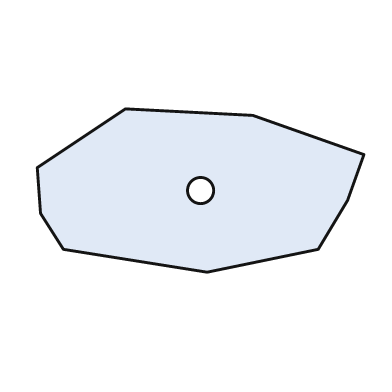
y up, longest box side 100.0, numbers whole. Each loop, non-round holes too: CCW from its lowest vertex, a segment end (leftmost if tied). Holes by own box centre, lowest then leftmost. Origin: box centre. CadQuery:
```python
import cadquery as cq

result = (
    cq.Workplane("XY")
    .moveTo(2.0, -25.0)
    .lineTo(36.0, -18.0)
    .lineTo(45.0, -3.0)
    .lineTo(50.0, 11.0)
    .lineTo(16.0, 23.0)
    .lineTo(-23.0, 25.0)
    .lineTo(-50.0, 7.0)
    .lineTo(-49.0, -7.0)
    .lineTo(-42.0, -18.0)
    .close()
    .moveTo(0.0, 0.0)
    .circle(4.0)
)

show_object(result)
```